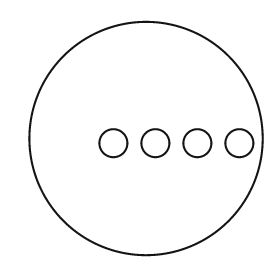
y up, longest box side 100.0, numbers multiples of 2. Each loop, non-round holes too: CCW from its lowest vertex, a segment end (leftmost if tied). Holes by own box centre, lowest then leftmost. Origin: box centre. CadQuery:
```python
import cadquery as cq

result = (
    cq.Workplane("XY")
    .moveTo(0.0, 0.0)
    .circle(50.0)
    .moveTo(-14.0, -2.0)
    .circle(6.0)
    .moveTo(4.0, -2.0)
    .circle(6.0)
    .moveTo(22.0, -2.0)
    .circle(6.0)
    .moveTo(40.0, -2.0)
    .circle(6.0)
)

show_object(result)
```